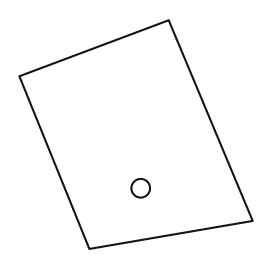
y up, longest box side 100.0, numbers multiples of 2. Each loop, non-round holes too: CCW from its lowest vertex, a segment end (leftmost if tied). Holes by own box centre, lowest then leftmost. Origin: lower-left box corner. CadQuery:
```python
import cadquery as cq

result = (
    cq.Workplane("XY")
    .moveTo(30.0, 0.0)
    .lineTo(100.0, 12.0)
    .lineTo(64.0, 98.0)
    .lineTo(0.0, 74.0)
    .close()
    .moveTo(52.0, 26.0)
    .circle(4.0)
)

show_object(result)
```